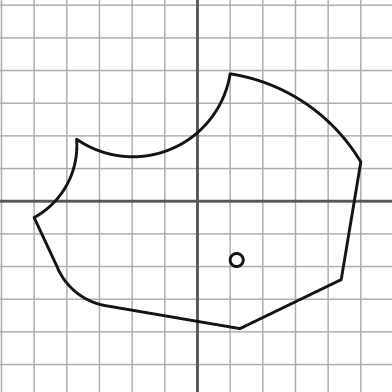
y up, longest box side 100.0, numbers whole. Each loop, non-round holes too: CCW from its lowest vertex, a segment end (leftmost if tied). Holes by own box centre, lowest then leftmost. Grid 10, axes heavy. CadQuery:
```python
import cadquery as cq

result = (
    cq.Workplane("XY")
    .moveTo(13.0, -39.0)
    .lineTo(44.0, -24.0)
    .lineTo(50.0, 12.0)
    .threePointArc((33.0, 30.0), (10.0, 39.0))
    .threePointArc((-8.0, 16.0), (-37.0, 19.0))
    .threePointArc((-40.0, 5.0), (-50.0, -5.0))
    .lineTo(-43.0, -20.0)
    .threePointArc((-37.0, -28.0), (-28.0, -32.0))
    .close()
    .moveTo(12.0, -18.0)
    .circle(2.0)
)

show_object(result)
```